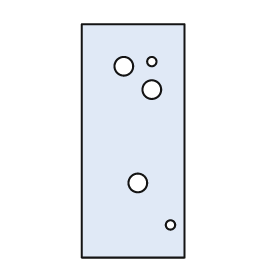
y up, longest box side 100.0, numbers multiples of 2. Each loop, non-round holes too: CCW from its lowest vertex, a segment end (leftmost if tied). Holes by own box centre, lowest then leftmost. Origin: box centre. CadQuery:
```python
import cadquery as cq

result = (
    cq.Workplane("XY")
    .moveTo(-22.0, -50.0)
    .lineTo(22.0, -50.0)
    .lineTo(22.0, 50.0)
    .lineTo(-22.0, 50.0)
    .close()
    .moveTo(16.0, -36.0)
    .circle(2.0)
    .moveTo(2.0, -18.0)
    .circle(4.0)
    .moveTo(8.0, 22.0)
    .circle(4.0)
    .moveTo(-4.0, 32.0)
    .circle(4.0)
    .moveTo(8.0, 34.0)
    .circle(2.0)
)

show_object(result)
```